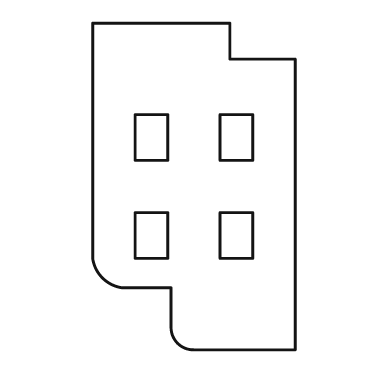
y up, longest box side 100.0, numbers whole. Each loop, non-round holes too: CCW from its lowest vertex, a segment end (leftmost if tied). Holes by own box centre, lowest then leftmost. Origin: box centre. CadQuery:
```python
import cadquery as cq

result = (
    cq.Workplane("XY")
    .moveTo(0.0, -50.0)
    .lineTo(31.0, -50.0)
    .lineTo(31.0, 39.0)
    .lineTo(11.0, 39.0)
    .lineTo(11.0, 50.0)
    .lineTo(-31.0, 50.0)
    .lineTo(-31.0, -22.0)
    .threePointArc((-28.0, -28.0), (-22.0, -31.0))
    .lineTo(-7.0, -31.0)
    .lineTo(-7.0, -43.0)
    .threePointArc((-5.0, -48.0), (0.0, -50.0))
    .close()
    .moveTo(-18.0, -22.0)
    .lineTo(-8.0, -22.0)
    .lineTo(-8.0, -8.0)
    .lineTo(-18.0, -8.0)
    .close()
    .moveTo(8.0, -22.0)
    .lineTo(18.0, -22.0)
    .lineTo(18.0, -8.0)
    .lineTo(8.0, -8.0)
    .close()
    .moveTo(-18.0, 8.0)
    .lineTo(-8.0, 8.0)
    .lineTo(-8.0, 22.0)
    .lineTo(-18.0, 22.0)
    .close()
    .moveTo(8.0, 8.0)
    .lineTo(18.0, 8.0)
    .lineTo(18.0, 22.0)
    .lineTo(8.0, 22.0)
    .close()
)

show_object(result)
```